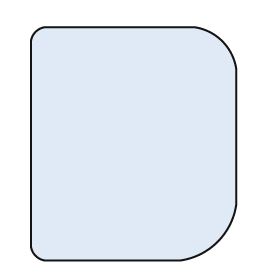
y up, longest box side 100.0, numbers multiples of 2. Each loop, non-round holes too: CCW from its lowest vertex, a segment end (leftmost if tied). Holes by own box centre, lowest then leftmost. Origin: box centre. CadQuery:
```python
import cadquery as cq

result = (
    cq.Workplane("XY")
    .moveTo(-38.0, -50.0)
    .lineTo(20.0, -50.0)
    .threePointArc((36.0, -42.0), (44.0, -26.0))
    .lineTo(44.0, 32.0)
    .threePointArc((38.0, 44.0), (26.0, 50.0))
    .lineTo(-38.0, 50.0)
    .threePointArc((-42.0, 48.0), (-44.0, 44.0))
    .lineTo(-44.0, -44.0)
    .threePointArc((-42.0, -48.0), (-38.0, -50.0))
    .close()
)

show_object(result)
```